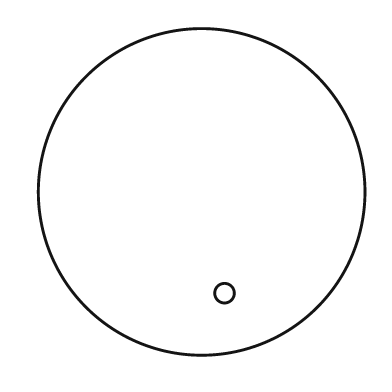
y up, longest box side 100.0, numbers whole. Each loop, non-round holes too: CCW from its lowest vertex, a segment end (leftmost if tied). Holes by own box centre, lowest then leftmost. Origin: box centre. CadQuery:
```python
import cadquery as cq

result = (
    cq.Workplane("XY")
    .moveTo(0.0, 0.0)
    .circle(50.0)
    .moveTo(7.0, -31.0)
    .circle(3.0)
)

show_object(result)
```